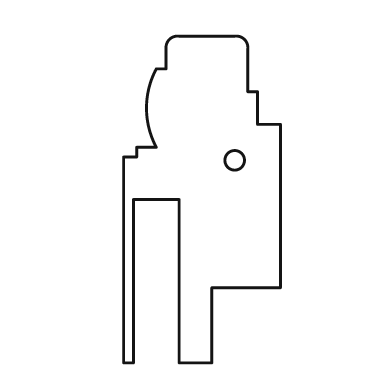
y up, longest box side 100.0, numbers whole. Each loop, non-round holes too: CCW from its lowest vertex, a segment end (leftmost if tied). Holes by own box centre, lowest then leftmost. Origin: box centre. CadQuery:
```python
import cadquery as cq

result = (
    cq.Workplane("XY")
    .moveTo(-24.0, -50.0)
    .lineTo(-21.0, -50.0)
    .lineTo(-21.0, 0.0)
    .lineTo(-7.0, 0.0)
    .lineTo(-7.0, -50.0)
    .lineTo(3.0, -50.0)
    .lineTo(3.0, -27.0)
    .lineTo(24.0, -27.0)
    .lineTo(24.0, 23.0)
    .lineTo(17.0, 23.0)
    .lineTo(17.0, 33.0)
    .lineTo(14.0, 33.0)
    .lineTo(14.0, 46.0)
    .threePointArc((13.0, 49.0), (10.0, 50.0))
    .lineTo(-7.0, 50.0)
    .threePointArc((-10.0, 49.0), (-11.0, 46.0))
    .lineTo(-11.0, 40.0)
    .lineTo(-14.0, 40.0)
    .threePointArc((-17.0, 28.0), (-14.0, 16.0))
    .lineTo(-20.0, 16.0)
    .lineTo(-20.0, 13.0)
    .lineTo(-24.0, 13.0)
    .close()
    .moveTo(10.0, 12.0)
    .circle(3.0)
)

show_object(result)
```